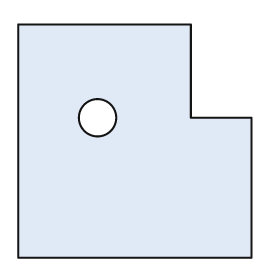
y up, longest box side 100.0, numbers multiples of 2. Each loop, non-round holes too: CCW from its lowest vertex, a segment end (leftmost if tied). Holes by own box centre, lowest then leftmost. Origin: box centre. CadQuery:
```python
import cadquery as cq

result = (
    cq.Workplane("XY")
    .moveTo(-50.0, -50.0)
    .lineTo(50.0, -50.0)
    .lineTo(50.0, 10.0)
    .lineTo(24.0, 10.0)
    .lineTo(24.0, 50.0)
    .lineTo(-50.0, 50.0)
    .close()
    .moveTo(-16.0, 10.0)
    .circle(8.0)
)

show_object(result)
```